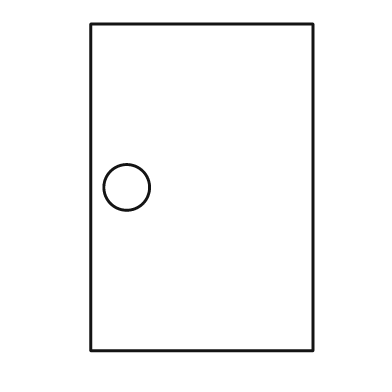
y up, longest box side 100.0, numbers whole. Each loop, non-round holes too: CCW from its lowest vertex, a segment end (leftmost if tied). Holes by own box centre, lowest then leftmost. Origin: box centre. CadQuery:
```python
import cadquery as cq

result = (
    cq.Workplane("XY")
    .moveTo(-34.0, -50.0)
    .lineTo(34.0, -50.0)
    .lineTo(34.0, 50.0)
    .lineTo(-34.0, 50.0)
    .close()
    .moveTo(-23.0, 0.0)
    .circle(7.0)
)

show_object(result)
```